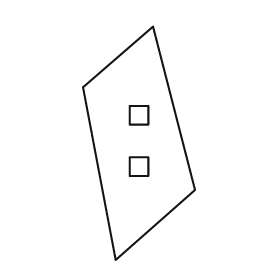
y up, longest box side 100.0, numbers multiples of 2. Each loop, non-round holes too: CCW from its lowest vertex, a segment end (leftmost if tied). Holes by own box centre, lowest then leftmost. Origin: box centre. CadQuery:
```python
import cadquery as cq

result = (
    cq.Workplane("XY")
    .moveTo(-10.0, -50.0)
    .lineTo(24.0, -20.0)
    .lineTo(6.0, 50.0)
    .lineTo(-24.0, 24.0)
    .close()
    .moveTo(-4.0, -14.0)
    .lineTo(4.0, -14.0)
    .lineTo(4.0, -6.0)
    .lineTo(-4.0, -6.0)
    .close()
    .moveTo(-4.0, 8.0)
    .lineTo(4.0, 8.0)
    .lineTo(4.0, 16.0)
    .lineTo(-4.0, 16.0)
    .close()
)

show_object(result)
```